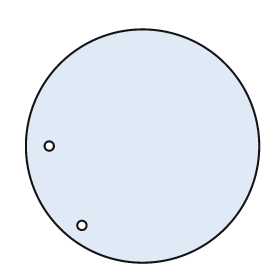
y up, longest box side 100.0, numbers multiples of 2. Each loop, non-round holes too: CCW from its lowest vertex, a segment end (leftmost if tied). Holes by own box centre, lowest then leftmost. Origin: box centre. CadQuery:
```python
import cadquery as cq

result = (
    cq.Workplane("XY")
    .moveTo(0.0, 0.0)
    .circle(50.0)
    .moveTo(-26.0, -34.0)
    .circle(2.0)
    .moveTo(-40.0, 0.0)
    .circle(2.0)
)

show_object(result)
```